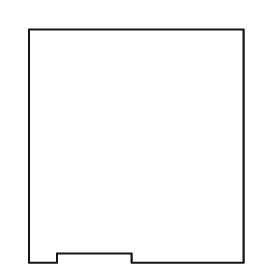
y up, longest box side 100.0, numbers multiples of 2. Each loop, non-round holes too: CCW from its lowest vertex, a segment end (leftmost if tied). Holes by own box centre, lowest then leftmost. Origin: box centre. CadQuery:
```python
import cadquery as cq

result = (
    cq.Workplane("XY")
    .moveTo(-46.0, -50.0)
    .lineTo(-34.0, -50.0)
    .lineTo(-34.0, -46.0)
    .lineTo(-2.0, -46.0)
    .lineTo(-2.0, -50.0)
    .lineTo(46.0, -50.0)
    .lineTo(46.0, 50.0)
    .lineTo(-46.0, 50.0)
    .close()
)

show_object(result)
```